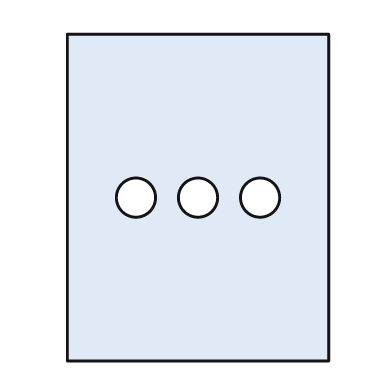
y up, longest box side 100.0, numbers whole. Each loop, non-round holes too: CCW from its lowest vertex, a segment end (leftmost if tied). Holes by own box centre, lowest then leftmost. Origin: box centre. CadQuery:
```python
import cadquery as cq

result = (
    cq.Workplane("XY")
    .moveTo(-40.0, -50.0)
    .lineTo(40.0, -50.0)
    .lineTo(40.0, 50.0)
    .lineTo(-40.0, 50.0)
    .close()
    .moveTo(-19.0, 0.0)
    .circle(6.0)
    .moveTo(0.0, 0.0)
    .circle(6.0)
    .moveTo(19.0, 0.0)
    .circle(6.0)
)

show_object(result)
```